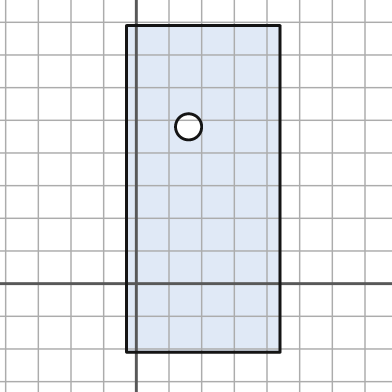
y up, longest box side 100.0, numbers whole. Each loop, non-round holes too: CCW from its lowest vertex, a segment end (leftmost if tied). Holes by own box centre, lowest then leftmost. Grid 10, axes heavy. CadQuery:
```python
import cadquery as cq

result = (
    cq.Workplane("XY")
    .moveTo(-3.0, -21.0)
    .lineTo(44.0, -21.0)
    .lineTo(44.0, 79.0)
    .lineTo(-3.0, 79.0)
    .close()
    .moveTo(16.0, 48.0)
    .circle(4.0)
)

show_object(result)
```